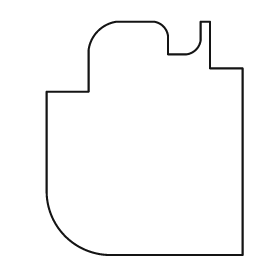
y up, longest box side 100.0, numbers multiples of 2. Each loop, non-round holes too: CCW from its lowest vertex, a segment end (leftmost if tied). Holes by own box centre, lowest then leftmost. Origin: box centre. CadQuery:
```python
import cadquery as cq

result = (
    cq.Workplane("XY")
    .moveTo(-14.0, -50.0)
    .lineTo(42.0, -50.0)
    .lineTo(42.0, 30.0)
    .lineTo(28.0, 30.0)
    .lineTo(28.0, 50.0)
    .lineTo(24.0, 50.0)
    .lineTo(24.0, 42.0)
    .threePointArc((22.0, 38.0), (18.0, 36.0))
    .lineTo(10.0, 36.0)
    .lineTo(10.0, 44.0)
    .threePointArc((8.0, 48.0), (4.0, 50.0))
    .lineTo(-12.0, 50.0)
    .threePointArc((-20.0, 46.0), (-24.0, 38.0))
    .lineTo(-24.0, 20.0)
    .lineTo(-42.0, 20.0)
    .lineTo(-42.0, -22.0)
    .threePointArc((-34.0, -42.0), (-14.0, -50.0))
    .close()
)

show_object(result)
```